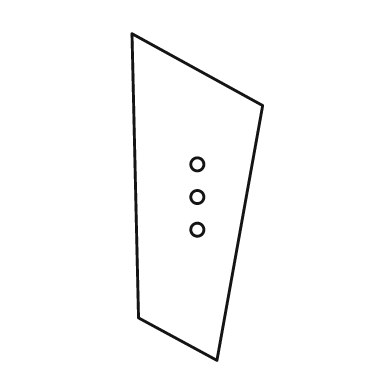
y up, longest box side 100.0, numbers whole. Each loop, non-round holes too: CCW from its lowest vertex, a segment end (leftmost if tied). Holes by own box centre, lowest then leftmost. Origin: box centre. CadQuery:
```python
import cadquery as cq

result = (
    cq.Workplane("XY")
    .moveTo(6.0, -50.0)
    .lineTo(20.0, 28.0)
    .lineTo(-20.0, 50.0)
    .lineTo(-18.0, -37.0)
    .close()
    .moveTo(0.0, -10.0)
    .circle(2.0)
    .moveTo(0.0, 0.0)
    .circle(2.0)
    .moveTo(0.0, 10.0)
    .circle(2.0)
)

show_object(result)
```